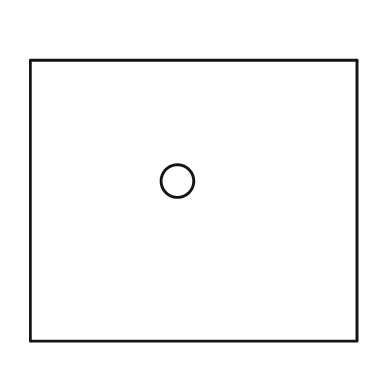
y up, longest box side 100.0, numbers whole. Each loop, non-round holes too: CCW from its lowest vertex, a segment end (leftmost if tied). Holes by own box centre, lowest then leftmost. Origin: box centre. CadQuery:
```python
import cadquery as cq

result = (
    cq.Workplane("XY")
    .moveTo(-50.0, -43.0)
    .lineTo(50.0, -43.0)
    .lineTo(50.0, 43.0)
    .lineTo(-50.0, 43.0)
    .close()
    .moveTo(-5.0, 6.0)
    .circle(5.0)
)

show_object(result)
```